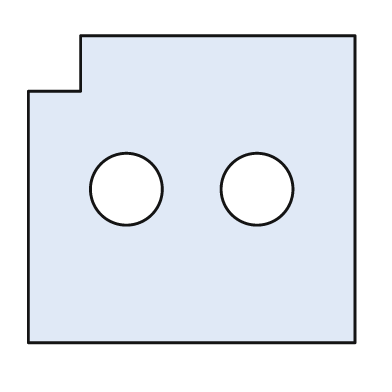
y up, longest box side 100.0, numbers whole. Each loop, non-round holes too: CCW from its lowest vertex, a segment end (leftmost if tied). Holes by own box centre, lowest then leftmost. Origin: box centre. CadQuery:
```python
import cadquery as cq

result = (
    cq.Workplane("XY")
    .moveTo(-50.0, -47.0)
    .lineTo(50.0, -47.0)
    .lineTo(50.0, 47.0)
    .lineTo(-34.0, 47.0)
    .lineTo(-34.0, 30.0)
    .lineTo(-50.0, 30.0)
    .close()
    .moveTo(-20.0, 0.0)
    .circle(11.0)
    .moveTo(20.0, 0.0)
    .circle(11.0)
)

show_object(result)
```